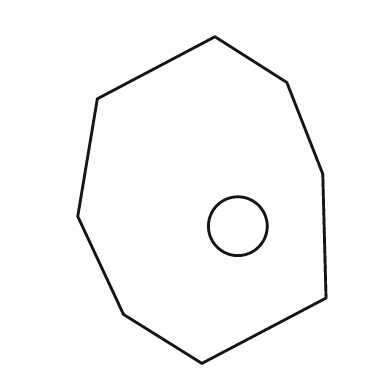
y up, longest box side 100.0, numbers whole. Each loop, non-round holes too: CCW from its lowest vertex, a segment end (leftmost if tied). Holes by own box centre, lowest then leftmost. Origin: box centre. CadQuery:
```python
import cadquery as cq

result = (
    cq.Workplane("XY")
    .moveTo(0.0, -50.0)
    .lineTo(38.0, -30.0)
    .lineTo(37.0, 8.0)
    .lineTo(26.0, 36.0)
    .lineTo(4.0, 50.0)
    .lineTo(-32.0, 31.0)
    .lineTo(-38.0, -5.0)
    .lineTo(-24.0, -35.0)
    .close()
    .moveTo(11.0, -8.0)
    .circle(9.0)
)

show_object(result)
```